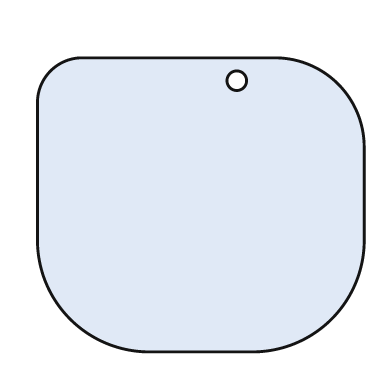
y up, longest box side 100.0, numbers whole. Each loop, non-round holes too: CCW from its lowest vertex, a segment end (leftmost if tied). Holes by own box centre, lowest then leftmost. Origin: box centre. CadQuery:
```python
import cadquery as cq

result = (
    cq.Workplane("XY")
    .moveTo(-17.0, -45.0)
    .lineTo(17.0, -45.0)
    .threePointArc((40.0, -35.0), (50.0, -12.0))
    .lineTo(50.0, 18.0)
    .threePointArc((42.0, 37.0), (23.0, 45.0))
    .lineTo(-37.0, 45.0)
    .threePointArc((-46.0, 41.0), (-50.0, 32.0))
    .lineTo(-50.0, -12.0)
    .threePointArc((-40.0, -35.0), (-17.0, -45.0))
    .close()
    .moveTo(11.0, 38.0)
    .circle(3.0)
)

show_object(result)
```